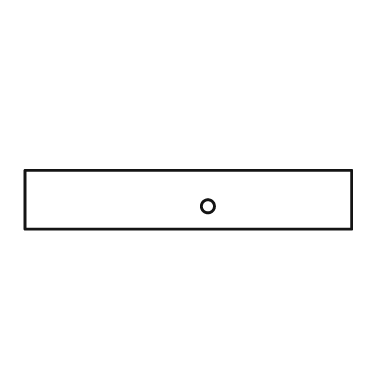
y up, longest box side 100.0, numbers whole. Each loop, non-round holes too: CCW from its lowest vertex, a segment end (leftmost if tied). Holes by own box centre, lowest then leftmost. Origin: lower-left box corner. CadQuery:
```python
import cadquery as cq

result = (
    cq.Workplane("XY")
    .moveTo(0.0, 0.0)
    .lineTo(100.0, 0.0)
    .lineTo(100.0, 18.0)
    .lineTo(0.0, 18.0)
    .close()
    .moveTo(56.0, 7.0)
    .circle(2.0)
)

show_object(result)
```